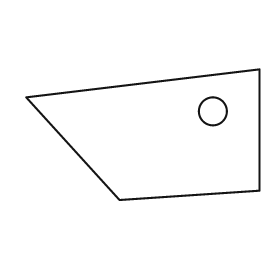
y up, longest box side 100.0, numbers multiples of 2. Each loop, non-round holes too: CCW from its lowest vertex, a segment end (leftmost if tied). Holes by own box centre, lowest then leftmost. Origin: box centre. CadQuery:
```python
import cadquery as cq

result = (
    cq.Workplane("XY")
    .moveTo(-10.0, -28.0)
    .lineTo(50.0, -24.0)
    .lineTo(50.0, 28.0)
    .lineTo(-50.0, 16.0)
    .close()
    .moveTo(30.0, 10.0)
    .circle(6.0)
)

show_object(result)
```